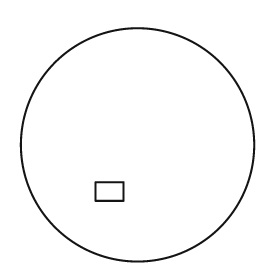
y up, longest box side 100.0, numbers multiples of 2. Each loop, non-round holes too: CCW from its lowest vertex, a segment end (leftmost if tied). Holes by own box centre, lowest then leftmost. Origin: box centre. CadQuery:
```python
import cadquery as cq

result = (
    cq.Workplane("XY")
    .moveTo(0.0, 0.0)
    .circle(50.0)
    .moveTo(-18.0, -24.0)
    .lineTo(-6.0, -24.0)
    .lineTo(-6.0, -16.0)
    .lineTo(-18.0, -16.0)
    .close()
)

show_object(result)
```